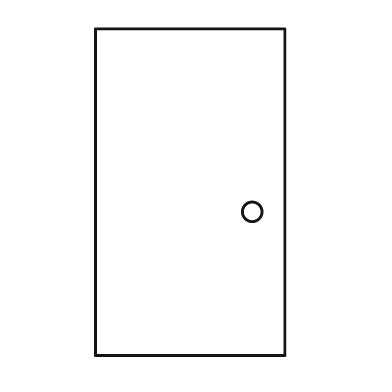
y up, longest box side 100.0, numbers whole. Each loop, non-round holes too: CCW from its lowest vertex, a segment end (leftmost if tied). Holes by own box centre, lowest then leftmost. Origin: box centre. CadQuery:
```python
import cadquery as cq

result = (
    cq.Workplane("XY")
    .moveTo(-29.0, -50.0)
    .lineTo(29.0, -50.0)
    .lineTo(29.0, 50.0)
    .lineTo(-29.0, 50.0)
    .close()
    .moveTo(19.0, -6.0)
    .circle(3.0)
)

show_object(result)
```